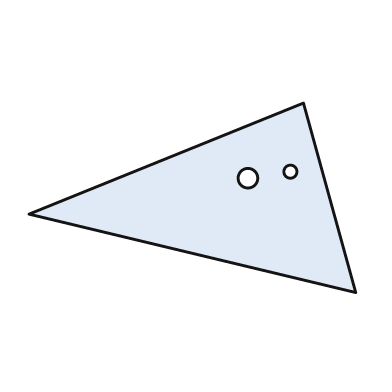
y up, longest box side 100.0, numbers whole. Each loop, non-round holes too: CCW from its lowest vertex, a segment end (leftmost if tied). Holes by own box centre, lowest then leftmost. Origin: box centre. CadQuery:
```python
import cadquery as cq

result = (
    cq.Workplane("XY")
    .moveTo(50.0, -29.0)
    .lineTo(34.0, 29.0)
    .lineTo(-50.0, -5.0)
    .close()
    .moveTo(17.0, 6.0)
    .circle(3.0)
    .moveTo(30.0, 8.0)
    .circle(2.0)
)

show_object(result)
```